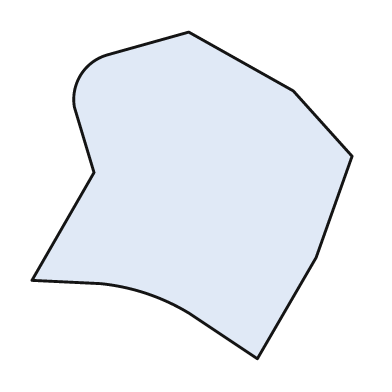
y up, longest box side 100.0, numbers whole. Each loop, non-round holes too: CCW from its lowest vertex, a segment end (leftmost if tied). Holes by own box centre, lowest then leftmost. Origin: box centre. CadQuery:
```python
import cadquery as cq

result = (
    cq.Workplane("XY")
    .moveTo(20.0, -50.0)
    .lineTo(38.0, -19.0)
    .lineTo(49.0, 12.0)
    .lineTo(31.0, 32.0)
    .lineTo(-1.0, 50.0)
    .lineTo(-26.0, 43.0)
    .threePointArc((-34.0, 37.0), (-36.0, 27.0))
    .lineTo(-30.0, 7.0)
    .lineTo(-49.0, -26.0)
    .lineTo(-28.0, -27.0)
    .threePointArc((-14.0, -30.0), (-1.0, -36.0))
    .close()
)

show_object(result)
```